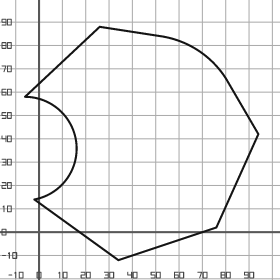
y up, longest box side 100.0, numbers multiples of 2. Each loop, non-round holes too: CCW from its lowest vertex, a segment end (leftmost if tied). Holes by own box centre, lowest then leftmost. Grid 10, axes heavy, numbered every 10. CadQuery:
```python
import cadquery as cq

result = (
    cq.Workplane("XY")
    .moveTo(34.0, -12.0)
    .lineTo(76.0, 2.0)
    .lineTo(94.0, 42.0)
    .lineTo(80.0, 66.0)
    .threePointArc((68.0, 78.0), (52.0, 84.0))
    .lineTo(26.0, 88.0)
    .lineTo(-6.0, 58.0)
    .threePointArc((16.0, 38.0), (-2.0, 14.0))
    .close()
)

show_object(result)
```